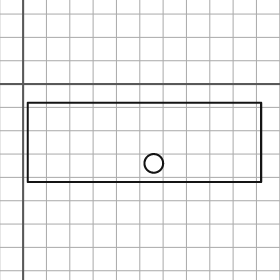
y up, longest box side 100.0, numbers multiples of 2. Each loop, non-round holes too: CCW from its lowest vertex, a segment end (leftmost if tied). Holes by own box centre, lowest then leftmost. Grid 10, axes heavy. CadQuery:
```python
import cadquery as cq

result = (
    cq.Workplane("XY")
    .moveTo(2.0, -42.0)
    .lineTo(102.0, -42.0)
    .lineTo(102.0, -8.0)
    .lineTo(2.0, -8.0)
    .close()
    .moveTo(56.0, -34.0)
    .circle(4.0)
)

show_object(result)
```